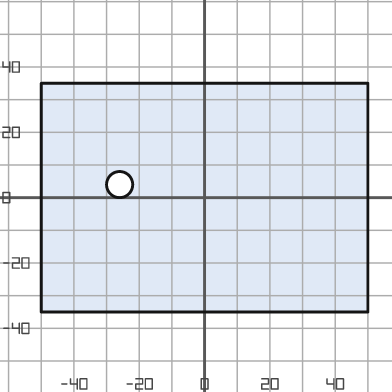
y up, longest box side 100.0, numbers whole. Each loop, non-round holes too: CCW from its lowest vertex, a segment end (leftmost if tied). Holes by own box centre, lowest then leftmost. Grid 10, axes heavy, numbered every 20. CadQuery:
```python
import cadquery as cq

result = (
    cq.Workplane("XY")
    .moveTo(-50.0, -35.0)
    .lineTo(50.0, -35.0)
    .lineTo(50.0, 35.0)
    .lineTo(-50.0, 35.0)
    .close()
    .moveTo(-26.0, 4.0)
    .circle(4.0)
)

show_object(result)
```